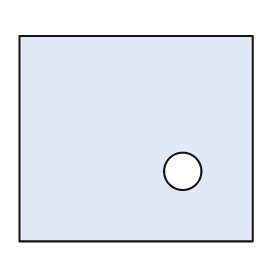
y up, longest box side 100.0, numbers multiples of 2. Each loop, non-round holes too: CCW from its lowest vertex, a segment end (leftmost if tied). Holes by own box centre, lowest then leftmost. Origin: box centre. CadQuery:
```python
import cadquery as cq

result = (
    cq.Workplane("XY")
    .moveTo(-50.0, -44.0)
    .lineTo(50.0, -44.0)
    .lineTo(50.0, 44.0)
    .lineTo(-50.0, 44.0)
    .close()
    .moveTo(20.0, -14.0)
    .circle(8.0)
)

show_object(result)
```